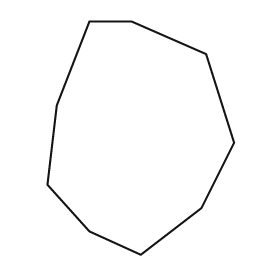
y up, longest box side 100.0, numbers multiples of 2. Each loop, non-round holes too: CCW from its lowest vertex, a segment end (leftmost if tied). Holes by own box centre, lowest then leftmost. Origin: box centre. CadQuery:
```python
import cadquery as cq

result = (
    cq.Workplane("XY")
    .moveTo(0.0, -50.0)
    .lineTo(26.0, -30.0)
    .lineTo(40.0, -2.0)
    .lineTo(28.0, 36.0)
    .lineTo(-4.0, 50.0)
    .lineTo(-22.0, 50.0)
    .lineTo(-36.0, 14.0)
    .lineTo(-40.0, -20.0)
    .lineTo(-22.0, -40.0)
    .close()
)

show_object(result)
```